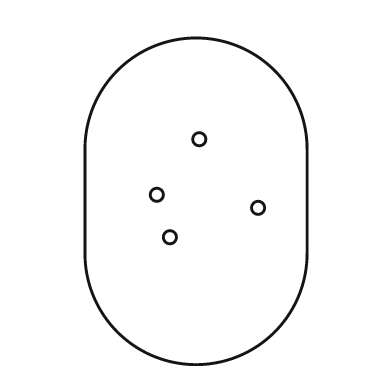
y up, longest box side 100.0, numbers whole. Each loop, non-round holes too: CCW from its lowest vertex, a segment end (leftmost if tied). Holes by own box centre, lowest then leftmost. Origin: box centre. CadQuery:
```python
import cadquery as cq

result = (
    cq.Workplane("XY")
    .moveTo(-34.0, -16.0)
    .threePointArc((0.0, -50.0), (34.0, -16.0))
    .lineTo(34.0, 16.0)
    .threePointArc((0.0, 50.0), (-34.0, 16.0))
    .close()
    .moveTo(-8.0, -11.0)
    .circle(2.0)
    .moveTo(19.0, -2.0)
    .circle(2.0)
    .moveTo(-12.0, 2.0)
    .circle(2.0)
    .moveTo(1.0, 19.0)
    .circle(2.0)
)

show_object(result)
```